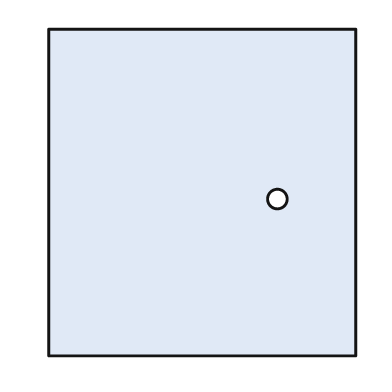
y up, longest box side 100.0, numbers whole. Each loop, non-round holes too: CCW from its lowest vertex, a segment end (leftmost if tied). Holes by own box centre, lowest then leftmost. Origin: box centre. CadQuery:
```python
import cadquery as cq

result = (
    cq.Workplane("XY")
    .moveTo(-47.0, -50.0)
    .lineTo(47.0, -50.0)
    .lineTo(47.0, 50.0)
    .lineTo(-47.0, 50.0)
    .close()
    .moveTo(23.0, -2.0)
    .circle(3.0)
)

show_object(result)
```